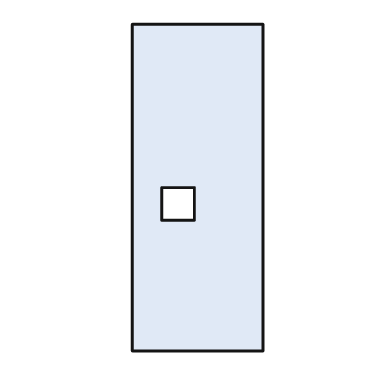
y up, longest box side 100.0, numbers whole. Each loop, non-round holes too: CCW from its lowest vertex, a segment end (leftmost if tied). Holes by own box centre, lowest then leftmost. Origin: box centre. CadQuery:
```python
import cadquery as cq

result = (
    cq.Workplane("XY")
    .moveTo(-20.0, -50.0)
    .lineTo(20.0, -50.0)
    .lineTo(20.0, 50.0)
    .lineTo(-20.0, 50.0)
    .close()
    .moveTo(-11.0, -10.0)
    .lineTo(-1.0, -10.0)
    .lineTo(-1.0, 0.0)
    .lineTo(-11.0, 0.0)
    .close()
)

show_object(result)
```